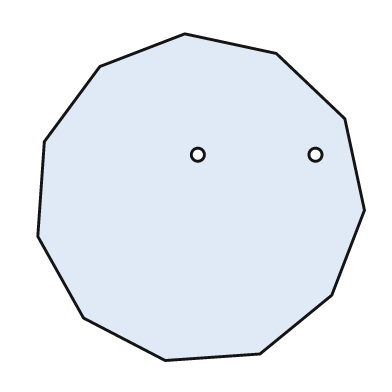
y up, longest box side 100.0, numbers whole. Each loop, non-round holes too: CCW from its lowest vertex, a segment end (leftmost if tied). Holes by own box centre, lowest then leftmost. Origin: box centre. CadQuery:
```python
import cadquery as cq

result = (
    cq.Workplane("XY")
    .moveTo(-11.0, -50.0)
    .lineTo(18.0, -48.0)
    .lineTo(40.0, -30.0)
    .lineTo(50.0, -4.0)
    .lineTo(44.0, 24.0)
    .lineTo(23.0, 44.0)
    .lineTo(-5.0, 50.0)
    .lineTo(-31.0, 40.0)
    .lineTo(-48.0, 17.0)
    .lineTo(-50.0, -12.0)
    .lineTo(-36.0, -37.0)
    .close()
    .moveTo(-1.0, 13.0)
    .circle(2.0)
    .moveTo(35.0, 13.0)
    .circle(2.0)
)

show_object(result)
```